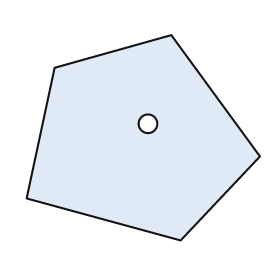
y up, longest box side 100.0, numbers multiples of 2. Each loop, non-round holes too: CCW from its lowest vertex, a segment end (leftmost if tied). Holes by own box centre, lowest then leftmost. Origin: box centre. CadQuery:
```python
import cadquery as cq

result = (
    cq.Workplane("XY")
    .moveTo(16.0, -44.0)
    .lineTo(50.0, -8.0)
    .lineTo(12.0, 44.0)
    .lineTo(-38.0, 30.0)
    .lineTo(-50.0, -26.0)
    .close()
    .moveTo(2.0, 6.0)
    .circle(4.0)
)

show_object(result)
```